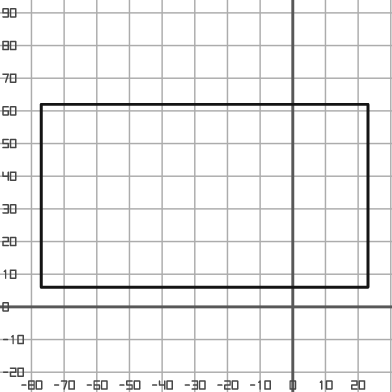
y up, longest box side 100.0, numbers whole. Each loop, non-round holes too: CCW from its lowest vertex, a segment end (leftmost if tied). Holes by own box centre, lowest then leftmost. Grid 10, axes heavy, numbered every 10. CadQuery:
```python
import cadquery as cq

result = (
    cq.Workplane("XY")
    .moveTo(-77.0, 6.0)
    .lineTo(23.0, 6.0)
    .lineTo(23.0, 62.0)
    .lineTo(-77.0, 62.0)
    .close()
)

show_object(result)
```